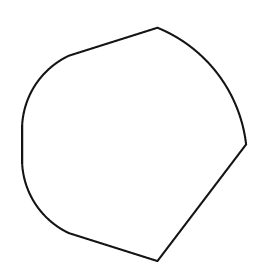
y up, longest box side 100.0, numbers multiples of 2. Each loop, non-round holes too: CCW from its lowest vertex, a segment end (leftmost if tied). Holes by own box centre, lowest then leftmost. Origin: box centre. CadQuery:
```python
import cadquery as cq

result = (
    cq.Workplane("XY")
    .moveTo(10.0, -50.0)
    .lineTo(48.0, 0.0)
    .threePointArc((36.0, 30.0), (10.0, 50.0))
    .lineTo(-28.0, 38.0)
    .threePointArc((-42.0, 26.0), (-48.0, 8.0))
    .lineTo(-48.0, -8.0)
    .threePointArc((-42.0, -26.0), (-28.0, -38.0))
    .close()
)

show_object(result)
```